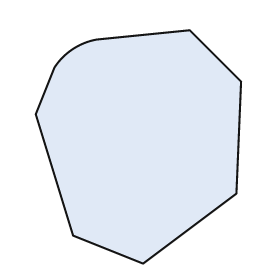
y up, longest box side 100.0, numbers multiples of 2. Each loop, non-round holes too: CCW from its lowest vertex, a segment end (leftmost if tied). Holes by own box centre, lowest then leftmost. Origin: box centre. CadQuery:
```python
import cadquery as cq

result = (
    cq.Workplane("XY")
    .moveTo(2.0, -50.0)
    .lineTo(42.0, -20.0)
    .lineTo(44.0, 28.0)
    .lineTo(22.0, 50.0)
    .lineTo(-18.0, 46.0)
    .threePointArc((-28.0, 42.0), (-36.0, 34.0))
    .lineTo(-44.0, 14.0)
    .lineTo(-28.0, -38.0)
    .close()
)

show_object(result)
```